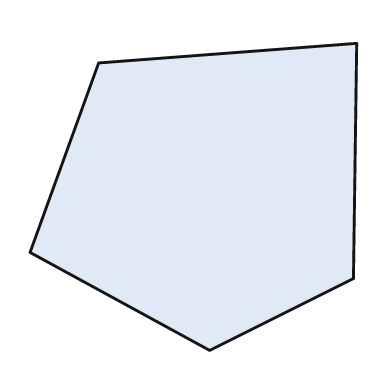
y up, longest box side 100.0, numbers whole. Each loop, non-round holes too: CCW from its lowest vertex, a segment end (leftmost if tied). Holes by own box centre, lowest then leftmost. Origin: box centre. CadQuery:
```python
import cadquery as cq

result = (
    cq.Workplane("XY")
    .moveTo(5.0, -47.0)
    .lineTo(49.0, -25.0)
    .lineTo(50.0, 47.0)
    .lineTo(-29.0, 41.0)
    .lineTo(-50.0, -17.0)
    .close()
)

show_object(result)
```